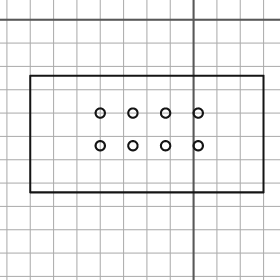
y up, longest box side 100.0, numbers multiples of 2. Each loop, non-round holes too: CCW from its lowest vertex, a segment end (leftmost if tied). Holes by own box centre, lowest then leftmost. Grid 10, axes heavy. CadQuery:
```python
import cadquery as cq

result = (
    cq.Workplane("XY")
    .moveTo(-70.0, -74.0)
    .lineTo(30.0, -74.0)
    .lineTo(30.0, -24.0)
    .lineTo(-70.0, -24.0)
    .close()
    .moveTo(-40.0, -54.0)
    .circle(2.0)
    .moveTo(-26.0, -54.0)
    .circle(2.0)
    .moveTo(-12.0, -54.0)
    .circle(2.0)
    .moveTo(2.0, -54.0)
    .circle(2.0)
    .moveTo(-40.0, -40.0)
    .circle(2.0)
    .moveTo(-26.0, -40.0)
    .circle(2.0)
    .moveTo(-12.0, -40.0)
    .circle(2.0)
    .moveTo(2.0, -40.0)
    .circle(2.0)
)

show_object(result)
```